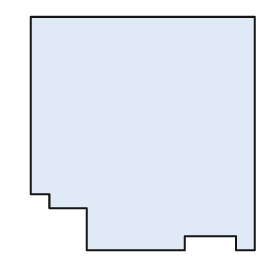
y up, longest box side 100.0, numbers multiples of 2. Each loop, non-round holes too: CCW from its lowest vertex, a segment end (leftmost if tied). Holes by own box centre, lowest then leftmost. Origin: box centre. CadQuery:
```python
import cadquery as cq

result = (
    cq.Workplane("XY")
    .moveTo(-24.0, -50.0)
    .lineTo(18.0, -50.0)
    .lineTo(18.0, -44.0)
    .lineTo(40.0, -44.0)
    .lineTo(40.0, -50.0)
    .lineTo(48.0, -50.0)
    .lineTo(48.0, 50.0)
    .lineTo(-48.0, 50.0)
    .lineTo(-48.0, -26.0)
    .lineTo(-40.0, -26.0)
    .lineTo(-40.0, -32.0)
    .lineTo(-24.0, -32.0)
    .close()
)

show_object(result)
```